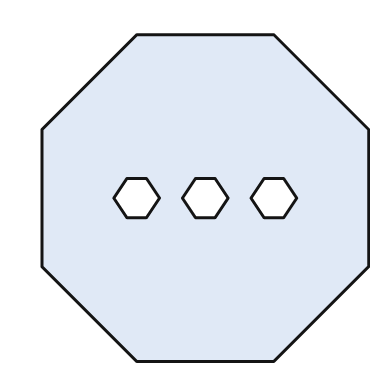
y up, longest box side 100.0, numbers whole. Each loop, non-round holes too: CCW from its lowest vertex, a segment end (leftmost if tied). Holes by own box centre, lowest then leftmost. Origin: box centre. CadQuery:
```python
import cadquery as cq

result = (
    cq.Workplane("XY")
    .moveTo(-21.0, -50.0)
    .lineTo(21.0, -50.0)
    .lineTo(50.0, -21.0)
    .lineTo(50.0, 21.0)
    .lineTo(21.0, 50.0)
    .lineTo(-21.0, 50.0)
    .lineTo(-50.0, 21.0)
    .lineTo(-50.0, -21.0)
    .close()
    .moveTo(-24.0, -6.0)
    .lineTo(-18.0, -6.0)
    .lineTo(-14.0, 0.0)
    .lineTo(-18.0, 6.0)
    .lineTo(-24.0, 6.0)
    .lineTo(-28.0, 0.0)
    .close()
    .moveTo(-3.0, -6.0)
    .lineTo(3.0, -6.0)
    .lineTo(7.0, 0.0)
    .lineTo(3.0, 6.0)
    .lineTo(-3.0, 6.0)
    .lineTo(-7.0, 0.0)
    .close()
    .moveTo(18.0, -6.0)
    .lineTo(24.0, -6.0)
    .lineTo(28.0, 0.0)
    .lineTo(24.0, 6.0)
    .lineTo(18.0, 6.0)
    .lineTo(14.0, 0.0)
    .close()
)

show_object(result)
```